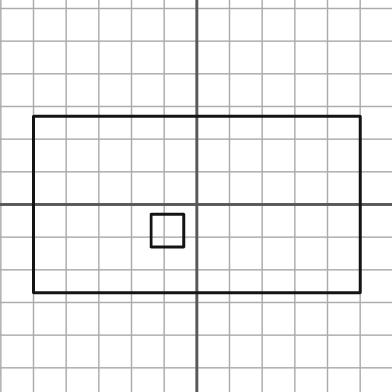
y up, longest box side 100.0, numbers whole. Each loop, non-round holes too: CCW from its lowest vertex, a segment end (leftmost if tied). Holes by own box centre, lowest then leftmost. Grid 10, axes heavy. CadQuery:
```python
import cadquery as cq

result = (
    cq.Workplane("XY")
    .moveTo(-50.0, -27.0)
    .lineTo(50.0, -27.0)
    .lineTo(50.0, 27.0)
    .lineTo(-50.0, 27.0)
    .close()
    .moveTo(-14.0, -13.0)
    .lineTo(-4.0, -13.0)
    .lineTo(-4.0, -3.0)
    .lineTo(-14.0, -3.0)
    .close()
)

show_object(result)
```